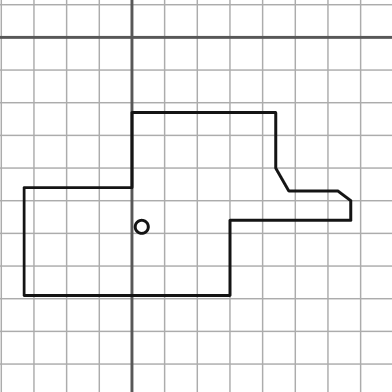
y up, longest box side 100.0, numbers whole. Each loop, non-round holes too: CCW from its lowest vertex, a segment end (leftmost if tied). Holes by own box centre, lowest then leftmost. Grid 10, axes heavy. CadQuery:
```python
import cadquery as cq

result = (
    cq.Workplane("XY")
    .moveTo(-33.0, -79.0)
    .lineTo(30.0, -79.0)
    .lineTo(30.0, -56.0)
    .lineTo(67.0, -56.0)
    .lineTo(67.0, -50.0)
    .lineTo(63.0, -47.0)
    .lineTo(48.0, -47.0)
    .lineTo(44.0, -40.0)
    .lineTo(44.0, -23.0)
    .lineTo(0.0, -23.0)
    .lineTo(0.0, -46.0)
    .lineTo(-33.0, -46.0)
    .close()
    .moveTo(3.0, -58.0)
    .circle(2.0)
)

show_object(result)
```